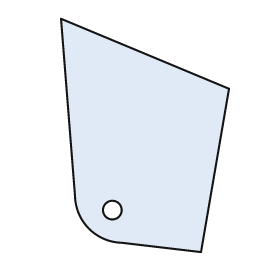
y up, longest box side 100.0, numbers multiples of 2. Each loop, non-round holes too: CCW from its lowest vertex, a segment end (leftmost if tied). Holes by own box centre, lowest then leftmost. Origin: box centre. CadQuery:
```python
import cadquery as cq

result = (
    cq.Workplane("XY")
    .moveTo(24.0, -50.0)
    .lineTo(36.0, 20.0)
    .lineTo(-36.0, 50.0)
    .lineTo(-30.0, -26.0)
    .threePointArc((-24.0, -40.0), (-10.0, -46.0))
    .close()
    .moveTo(-14.0, -32.0)
    .circle(4.0)
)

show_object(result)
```